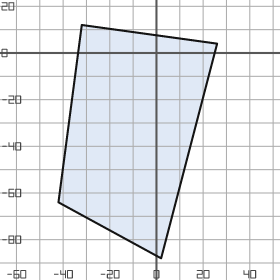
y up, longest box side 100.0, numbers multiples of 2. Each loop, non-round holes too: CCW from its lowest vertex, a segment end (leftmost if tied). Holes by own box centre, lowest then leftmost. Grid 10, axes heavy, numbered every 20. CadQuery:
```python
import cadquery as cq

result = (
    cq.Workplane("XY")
    .moveTo(2.0, -88.0)
    .lineTo(26.0, 4.0)
    .lineTo(-32.0, 12.0)
    .lineTo(-42.0, -64.0)
    .close()
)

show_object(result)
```